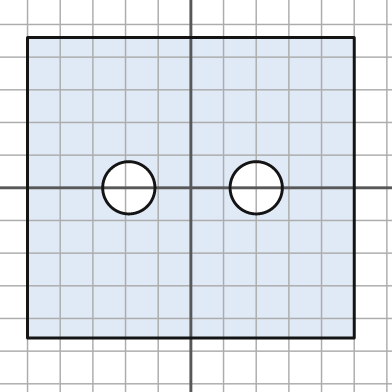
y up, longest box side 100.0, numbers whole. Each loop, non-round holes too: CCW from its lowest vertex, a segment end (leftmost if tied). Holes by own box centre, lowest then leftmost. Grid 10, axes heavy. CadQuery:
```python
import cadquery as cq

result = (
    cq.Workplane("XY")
    .moveTo(-50.0, -46.0)
    .lineTo(50.0, -46.0)
    .lineTo(50.0, 46.0)
    .lineTo(-50.0, 46.0)
    .close()
    .moveTo(-19.0, 0.0)
    .circle(8.0)
    .moveTo(20.0, 0.0)
    .circle(8.0)
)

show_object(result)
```